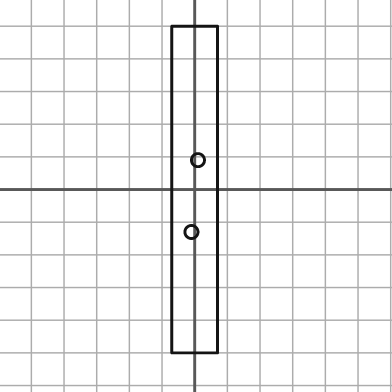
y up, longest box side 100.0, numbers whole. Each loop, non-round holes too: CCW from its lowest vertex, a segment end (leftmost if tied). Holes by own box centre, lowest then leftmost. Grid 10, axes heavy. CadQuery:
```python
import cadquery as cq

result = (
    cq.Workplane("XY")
    .moveTo(-7.0, -50.0)
    .lineTo(7.0, -50.0)
    .lineTo(7.0, 50.0)
    .lineTo(-7.0, 50.0)
    .close()
    .moveTo(-1.0, -13.0)
    .circle(2.0)
    .moveTo(1.0, 9.0)
    .circle(2.0)
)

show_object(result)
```